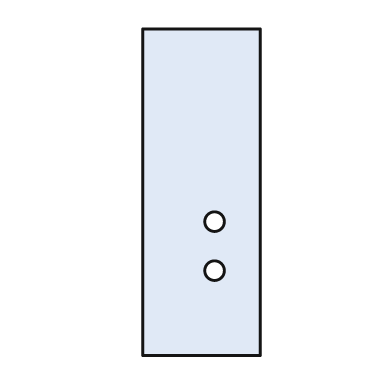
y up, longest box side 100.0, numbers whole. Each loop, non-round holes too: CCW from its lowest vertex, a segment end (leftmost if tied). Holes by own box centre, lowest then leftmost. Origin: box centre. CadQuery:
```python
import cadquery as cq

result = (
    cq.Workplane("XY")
    .moveTo(-18.0, -50.0)
    .lineTo(18.0, -50.0)
    .lineTo(18.0, 50.0)
    .lineTo(-18.0, 50.0)
    .close()
    .moveTo(4.0, -24.0)
    .circle(3.0)
    .moveTo(4.0, -9.0)
    .circle(3.0)
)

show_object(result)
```